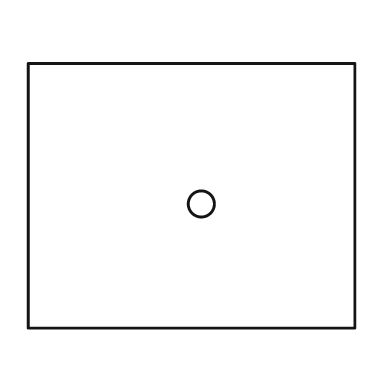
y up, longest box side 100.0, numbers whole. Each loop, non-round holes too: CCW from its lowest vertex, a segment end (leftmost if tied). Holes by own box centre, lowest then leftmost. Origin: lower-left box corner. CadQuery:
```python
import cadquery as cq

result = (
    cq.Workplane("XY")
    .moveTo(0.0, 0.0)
    .lineTo(100.0, 0.0)
    .lineTo(100.0, 81.0)
    .lineTo(0.0, 81.0)
    .close()
    .moveTo(53.0, 38.0)
    .circle(4.0)
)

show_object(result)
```